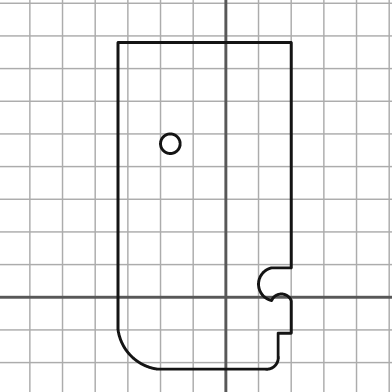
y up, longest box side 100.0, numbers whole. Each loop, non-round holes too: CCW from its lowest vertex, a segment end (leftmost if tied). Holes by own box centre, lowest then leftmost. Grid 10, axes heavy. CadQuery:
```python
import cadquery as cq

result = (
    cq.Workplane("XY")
    .moveTo(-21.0, -22.0)
    .lineTo(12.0, -22.0)
    .threePointArc((15.0, -21.0), (16.0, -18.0))
    .lineTo(16.0, -11.0)
    .lineTo(20.0, -11.0)
    .lineTo(20.0, -1.0)
    .threePointArc((17.0, 1.0), (14.0, -1.0))
    .threePointArc((10.0, 4.0), (14.0, 9.0))
    .lineTo(20.0, 9.0)
    .lineTo(20.0, 78.0)
    .lineTo(-33.0, 78.0)
    .lineTo(-33.0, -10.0)
    .threePointArc((-29.0, -18.0), (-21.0, -22.0))
    .close()
    .moveTo(-17.0, 47.0)
    .circle(3.0)
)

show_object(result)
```